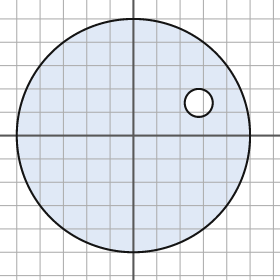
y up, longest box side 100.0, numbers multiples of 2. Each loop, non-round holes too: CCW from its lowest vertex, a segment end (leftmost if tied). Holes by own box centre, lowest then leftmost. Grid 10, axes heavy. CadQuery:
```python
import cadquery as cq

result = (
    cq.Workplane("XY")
    .moveTo(0.0, 0.0)
    .circle(50.0)
    .moveTo(28.0, 14.0)
    .circle(6.0)
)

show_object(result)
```